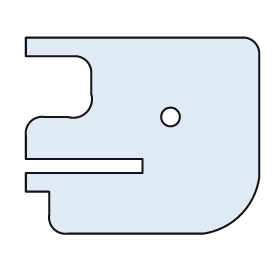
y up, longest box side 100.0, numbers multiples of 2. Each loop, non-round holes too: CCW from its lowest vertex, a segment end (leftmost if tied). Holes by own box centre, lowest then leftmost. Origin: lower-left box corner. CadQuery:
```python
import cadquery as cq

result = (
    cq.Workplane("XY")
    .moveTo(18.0, 0.0)
    .lineTo(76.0, 0.0)
    .threePointArc((92.0, 8.0), (100.0, 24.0))
    .lineTo(100.0, 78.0)
    .threePointArc((98.0, 82.0), (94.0, 84.0))
    .lineTo(0.0, 84.0)
    .lineTo(0.0, 76.0)
    .lineTo(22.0, 76.0)
    .threePointArc((26.0, 74.0), (28.0, 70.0))
    .lineTo(28.0, 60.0)
    .threePointArc((26.0, 52.0), (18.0, 50.0))
    .lineTo(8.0, 50.0)
    .threePointArc((2.0, 48.0), (0.0, 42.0))
    .lineTo(0.0, 32.0)
    .lineTo(50.0, 32.0)
    .lineTo(50.0, 26.0)
    .lineTo(0.0, 26.0)
    .lineTo(0.0, 18.0)
    .lineTo(10.0, 18.0)
    .lineTo(10.0, 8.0)
    .threePointArc((12.0, 2.0), (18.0, 0.0))
    .close()
    .moveTo(62.0, 50.0)
    .circle(4.0)
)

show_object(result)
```